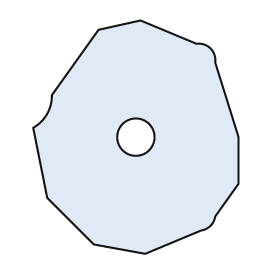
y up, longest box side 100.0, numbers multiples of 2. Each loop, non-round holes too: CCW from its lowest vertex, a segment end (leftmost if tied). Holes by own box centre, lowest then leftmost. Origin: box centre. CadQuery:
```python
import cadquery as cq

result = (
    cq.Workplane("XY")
    .moveTo(4.0, -50.0)
    .lineTo(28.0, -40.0)
    .threePointArc((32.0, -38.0), (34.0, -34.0))
    .lineTo(44.0, -20.0)
    .lineTo(44.0, 0.0)
    .lineTo(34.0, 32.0)
    .threePointArc((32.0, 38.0), (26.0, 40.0))
    .lineTo(2.0, 50.0)
    .lineTo(-16.0, 46.0)
    .lineTo(-36.0, 18.0)
    .threePointArc((-38.0, 10.0), (-44.0, 4.0))
    .lineTo(-38.0, -26.0)
    .lineTo(-18.0, -46.0)
    .close()
    .moveTo(0.0, 0.0)
    .circle(8.0)
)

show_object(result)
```